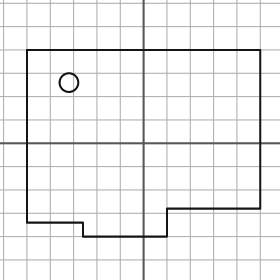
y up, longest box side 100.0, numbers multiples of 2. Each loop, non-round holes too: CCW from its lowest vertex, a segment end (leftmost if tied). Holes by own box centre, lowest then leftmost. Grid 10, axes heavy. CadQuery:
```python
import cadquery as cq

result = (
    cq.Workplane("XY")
    .moveTo(-26.0, -40.0)
    .lineTo(10.0, -40.0)
    .lineTo(10.0, -28.0)
    .lineTo(50.0, -28.0)
    .lineTo(50.0, 40.0)
    .lineTo(-50.0, 40.0)
    .lineTo(-50.0, -34.0)
    .lineTo(-26.0, -34.0)
    .close()
    .moveTo(-32.0, 26.0)
    .circle(4.0)
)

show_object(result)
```